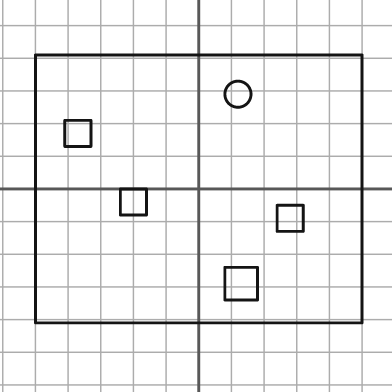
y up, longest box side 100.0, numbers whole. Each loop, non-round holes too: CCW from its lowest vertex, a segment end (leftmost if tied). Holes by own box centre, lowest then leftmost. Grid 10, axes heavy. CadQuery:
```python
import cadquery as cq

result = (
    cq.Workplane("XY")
    .moveTo(-50.0, -41.0)
    .lineTo(50.0, -41.0)
    .lineTo(50.0, 41.0)
    .lineTo(-50.0, 41.0)
    .close()
    .moveTo(8.0, -34.0)
    .lineTo(18.0, -34.0)
    .lineTo(18.0, -24.0)
    .lineTo(8.0, -24.0)
    .close()
    .moveTo(24.0, -13.0)
    .lineTo(32.0, -13.0)
    .lineTo(32.0, -5.0)
    .lineTo(24.0, -5.0)
    .close()
    .moveTo(-24.0, -8.0)
    .lineTo(-16.0, -8.0)
    .lineTo(-16.0, 0.0)
    .lineTo(-24.0, 0.0)
    .close()
    .moveTo(-41.0, 13.0)
    .lineTo(-33.0, 13.0)
    .lineTo(-33.0, 21.0)
    .lineTo(-41.0, 21.0)
    .close()
    .moveTo(12.0, 29.0)
    .circle(4.0)
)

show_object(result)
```